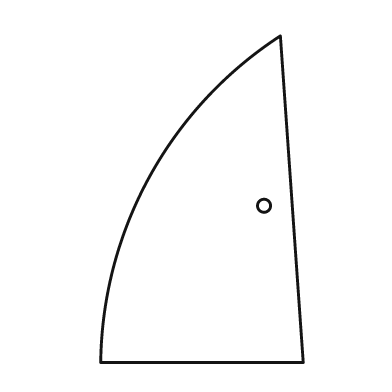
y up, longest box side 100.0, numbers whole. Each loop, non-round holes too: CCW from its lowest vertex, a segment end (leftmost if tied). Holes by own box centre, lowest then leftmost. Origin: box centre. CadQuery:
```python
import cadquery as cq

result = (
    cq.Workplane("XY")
    .moveTo(-31.0, -50.0)
    .lineTo(31.0, -50.0)
    .lineTo(24.0, 50.0)
    .threePointArc((-16.0, 7.0), (-31.0, -50.0))
    .close()
    .moveTo(19.0, -2.0)
    .circle(2.0)
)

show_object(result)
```